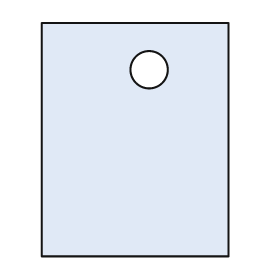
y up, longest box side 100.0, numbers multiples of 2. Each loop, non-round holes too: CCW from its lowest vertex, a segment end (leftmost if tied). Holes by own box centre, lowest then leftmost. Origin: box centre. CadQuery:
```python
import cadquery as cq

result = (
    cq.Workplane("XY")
    .moveTo(-40.0, -50.0)
    .lineTo(40.0, -50.0)
    .lineTo(40.0, 50.0)
    .lineTo(-40.0, 50.0)
    .close()
    .moveTo(6.0, 30.0)
    .circle(8.0)
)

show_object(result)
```